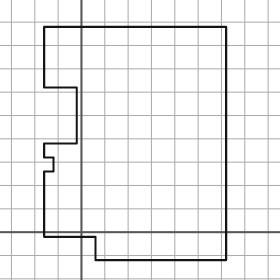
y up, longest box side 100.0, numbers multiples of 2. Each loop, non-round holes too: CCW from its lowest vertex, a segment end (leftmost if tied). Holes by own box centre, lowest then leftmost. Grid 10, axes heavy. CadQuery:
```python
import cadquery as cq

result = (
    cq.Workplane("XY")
    .moveTo(6.0, -12.0)
    .lineTo(62.0, -12.0)
    .lineTo(62.0, 88.0)
    .lineTo(-16.0, 88.0)
    .lineTo(-16.0, 62.0)
    .lineTo(-2.0, 62.0)
    .lineTo(-2.0, 38.0)
    .lineTo(-16.0, 38.0)
    .lineTo(-16.0, 32.0)
    .lineTo(-12.0, 32.0)
    .lineTo(-12.0, 26.0)
    .lineTo(-16.0, 26.0)
    .lineTo(-16.0, -2.0)
    .lineTo(6.0, -2.0)
    .close()
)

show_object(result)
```